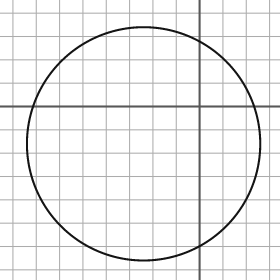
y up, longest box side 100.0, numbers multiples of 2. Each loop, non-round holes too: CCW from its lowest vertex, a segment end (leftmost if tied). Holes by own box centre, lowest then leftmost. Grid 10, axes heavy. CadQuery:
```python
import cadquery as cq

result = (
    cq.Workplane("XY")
    .moveTo(-24.0, -16.0)
    .circle(50.0)
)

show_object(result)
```